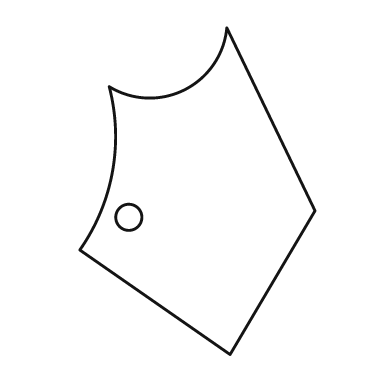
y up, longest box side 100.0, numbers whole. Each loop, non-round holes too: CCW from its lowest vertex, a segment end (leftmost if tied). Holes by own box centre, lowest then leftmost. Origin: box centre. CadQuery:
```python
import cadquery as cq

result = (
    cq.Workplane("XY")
    .moveTo(10.0, -50.0)
    .lineTo(36.0, -6.0)
    .lineTo(9.0, 50.0)
    .threePointArc((-4.0, 31.0), (-27.0, 32.0))
    .threePointArc((-26.0, 6.0), (-36.0, -18.0))
    .close()
    .moveTo(-21.0, -8.0)
    .circle(4.0)
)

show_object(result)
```